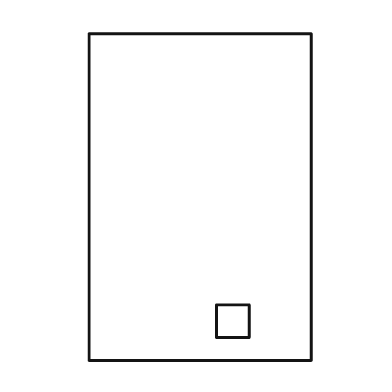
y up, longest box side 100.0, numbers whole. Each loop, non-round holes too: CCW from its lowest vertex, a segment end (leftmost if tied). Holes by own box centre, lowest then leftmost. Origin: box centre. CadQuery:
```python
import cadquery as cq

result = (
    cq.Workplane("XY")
    .moveTo(-34.0, -50.0)
    .lineTo(34.0, -50.0)
    .lineTo(34.0, 50.0)
    .lineTo(-34.0, 50.0)
    .close()
    .moveTo(5.0, -43.0)
    .lineTo(15.0, -43.0)
    .lineTo(15.0, -33.0)
    .lineTo(5.0, -33.0)
    .close()
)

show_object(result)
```